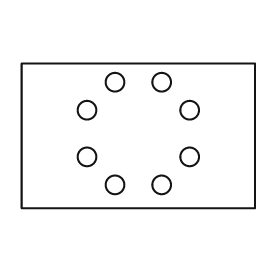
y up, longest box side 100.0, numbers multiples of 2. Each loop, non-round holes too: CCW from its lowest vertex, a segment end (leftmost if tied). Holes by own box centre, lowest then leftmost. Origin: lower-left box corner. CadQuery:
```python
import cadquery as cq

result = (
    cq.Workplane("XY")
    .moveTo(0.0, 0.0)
    .lineTo(100.0, 0.0)
    .lineTo(100.0, 62.0)
    .lineTo(0.0, 62.0)
    .close()
    .moveTo(40.0, 10.0)
    .circle(4.0)
    .moveTo(60.0, 10.0)
    .circle(4.0)
    .moveTo(28.0, 22.0)
    .circle(4.0)
    .moveTo(72.0, 22.0)
    .circle(4.0)
    .moveTo(28.0, 42.0)
    .circle(4.0)
    .moveTo(72.0, 42.0)
    .circle(4.0)
    .moveTo(40.0, 54.0)
    .circle(4.0)
    .moveTo(60.0, 54.0)
    .circle(4.0)
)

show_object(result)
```